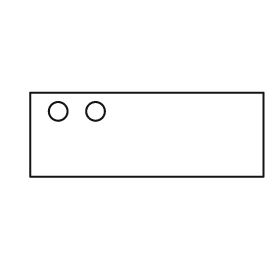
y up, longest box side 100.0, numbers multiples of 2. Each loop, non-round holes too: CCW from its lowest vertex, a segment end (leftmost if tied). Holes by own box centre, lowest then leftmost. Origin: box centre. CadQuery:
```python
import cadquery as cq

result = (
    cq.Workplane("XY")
    .moveTo(-50.0, -18.0)
    .lineTo(50.0, -18.0)
    .lineTo(50.0, 18.0)
    .lineTo(-50.0, 18.0)
    .close()
    .moveTo(-38.0, 10.0)
    .circle(4.0)
    .moveTo(-22.0, 10.0)
    .circle(4.0)
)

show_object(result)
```